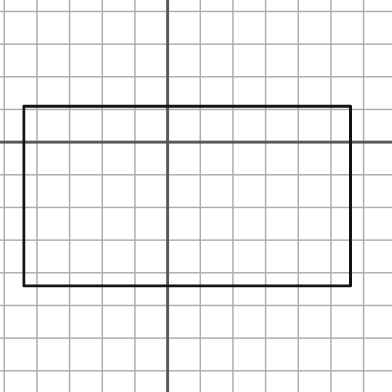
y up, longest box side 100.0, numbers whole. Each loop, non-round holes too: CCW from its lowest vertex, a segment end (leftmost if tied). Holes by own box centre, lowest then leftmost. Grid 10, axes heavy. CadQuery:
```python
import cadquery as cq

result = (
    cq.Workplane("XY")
    .moveTo(-44.0, -44.0)
    .lineTo(56.0, -44.0)
    .lineTo(56.0, 11.0)
    .lineTo(-44.0, 11.0)
    .close()
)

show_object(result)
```